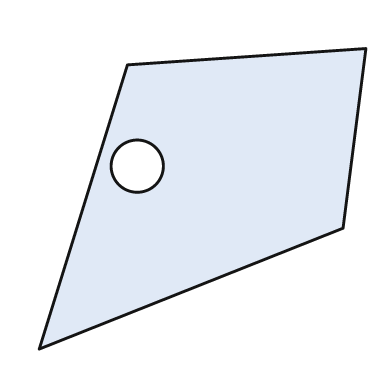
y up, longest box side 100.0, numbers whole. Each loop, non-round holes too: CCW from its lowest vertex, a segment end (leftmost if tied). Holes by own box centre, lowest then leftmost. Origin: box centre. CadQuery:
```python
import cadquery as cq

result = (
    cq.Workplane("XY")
    .moveTo(-50.0, -46.0)
    .lineTo(43.0, -9.0)
    .lineTo(50.0, 46.0)
    .lineTo(-23.0, 41.0)
    .close()
    .moveTo(-20.0, 10.0)
    .circle(8.0)
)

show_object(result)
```